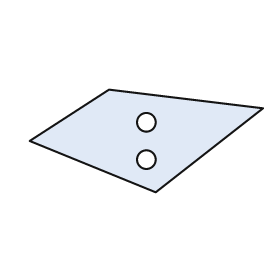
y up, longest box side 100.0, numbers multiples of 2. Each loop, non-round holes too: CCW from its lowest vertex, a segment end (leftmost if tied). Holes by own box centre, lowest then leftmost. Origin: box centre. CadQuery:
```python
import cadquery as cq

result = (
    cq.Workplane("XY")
    .moveTo(4.0, -22.0)
    .lineTo(50.0, 14.0)
    .lineTo(-16.0, 22.0)
    .lineTo(-50.0, 0.0)
    .close()
    .moveTo(0.0, -8.0)
    .circle(4.0)
    .moveTo(0.0, 8.0)
    .circle(4.0)
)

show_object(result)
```